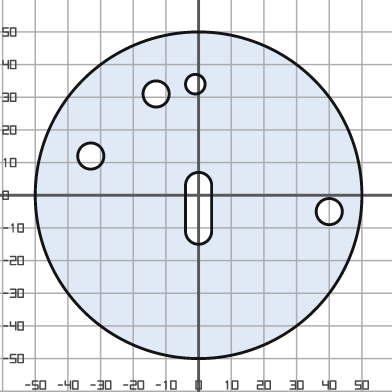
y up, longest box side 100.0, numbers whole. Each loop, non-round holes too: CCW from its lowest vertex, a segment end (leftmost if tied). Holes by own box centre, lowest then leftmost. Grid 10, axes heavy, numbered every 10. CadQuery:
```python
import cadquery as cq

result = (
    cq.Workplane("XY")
    .moveTo(0.0, 0.0)
    .circle(50.0)
    .moveTo(40.0, -5.0)
    .circle(4.0)
    .moveTo(-4.0, -11.0)
    .threePointArc((0.0, -15.0), (4.0, -11.0))
    .lineTo(4.0, 3.0)
    .threePointArc((0.0, 7.0), (-4.0, 3.0))
    .close()
    .moveTo(-33.0, 12.0)
    .circle(4.0)
    .moveTo(-13.0, 31.0)
    .circle(4.0)
    .moveTo(-1.0, 34.0)
    .circle(3.0)
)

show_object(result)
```